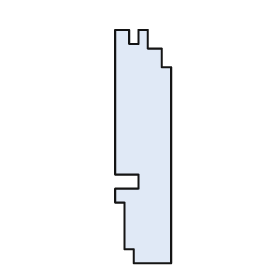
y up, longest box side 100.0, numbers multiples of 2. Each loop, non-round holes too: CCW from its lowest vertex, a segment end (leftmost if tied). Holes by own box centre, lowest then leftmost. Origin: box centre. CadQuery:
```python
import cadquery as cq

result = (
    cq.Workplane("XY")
    .moveTo(-4.0, -50.0)
    .lineTo(12.0, -50.0)
    .lineTo(12.0, 34.0)
    .lineTo(8.0, 34.0)
    .lineTo(8.0, 42.0)
    .lineTo(2.0, 42.0)
    .lineTo(2.0, 50.0)
    .lineTo(-2.0, 50.0)
    .lineTo(-2.0, 44.0)
    .lineTo(-6.0, 44.0)
    .lineTo(-6.0, 50.0)
    .lineTo(-12.0, 50.0)
    .lineTo(-12.0, -12.0)
    .lineTo(-2.0, -12.0)
    .lineTo(-2.0, -18.0)
    .lineTo(-12.0, -18.0)
    .lineTo(-12.0, -24.0)
    .lineTo(-8.0, -24.0)
    .lineTo(-8.0, -44.0)
    .lineTo(-4.0, -44.0)
    .close()
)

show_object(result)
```